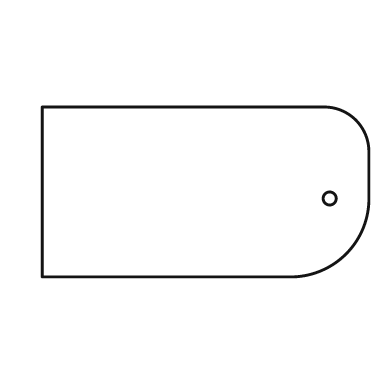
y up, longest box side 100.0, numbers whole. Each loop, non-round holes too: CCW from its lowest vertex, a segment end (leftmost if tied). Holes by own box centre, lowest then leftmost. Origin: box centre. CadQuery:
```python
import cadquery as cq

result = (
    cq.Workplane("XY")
    .moveTo(-50.0, -26.0)
    .lineTo(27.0, -26.0)
    .threePointArc((43.0, -19.0), (50.0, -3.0))
    .lineTo(50.0, 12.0)
    .threePointArc((46.0, 22.0), (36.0, 26.0))
    .lineTo(-50.0, 26.0)
    .close()
    .moveTo(38.0, -2.0)
    .circle(2.0)
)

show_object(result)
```